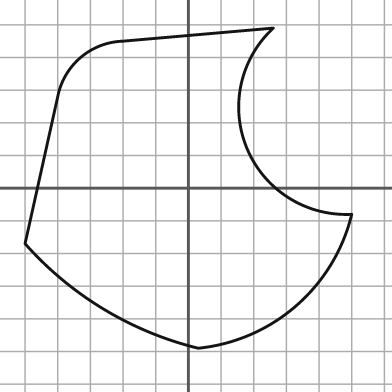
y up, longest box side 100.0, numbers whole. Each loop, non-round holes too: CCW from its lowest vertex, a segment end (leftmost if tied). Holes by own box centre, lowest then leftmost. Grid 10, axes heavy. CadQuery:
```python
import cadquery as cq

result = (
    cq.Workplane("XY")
    .moveTo(3.0, -49.0)
    .threePointArc((33.0, -36.0), (50.0, -8.0))
    .threePointArc((18.0, 12.0), (26.0, 49.0))
    .lineTo(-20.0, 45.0)
    .threePointArc((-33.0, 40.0), (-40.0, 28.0))
    .lineTo(-50.0, -17.0)
    .threePointArc((-26.0, -37.0), (3.0, -49.0))
    .close()
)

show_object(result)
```